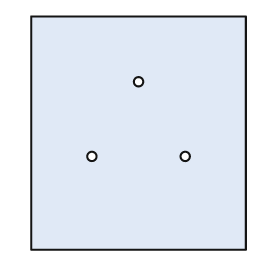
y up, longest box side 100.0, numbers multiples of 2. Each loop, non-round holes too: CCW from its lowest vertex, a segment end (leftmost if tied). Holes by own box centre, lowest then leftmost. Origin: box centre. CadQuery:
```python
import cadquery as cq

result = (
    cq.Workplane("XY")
    .moveTo(-46.0, -50.0)
    .lineTo(46.0, -50.0)
    .lineTo(46.0, 50.0)
    .lineTo(-46.0, 50.0)
    .close()
    .moveTo(-20.0, -10.0)
    .circle(2.0)
    .moveTo(20.0, -10.0)
    .circle(2.0)
    .moveTo(0.0, 22.0)
    .circle(2.0)
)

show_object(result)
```